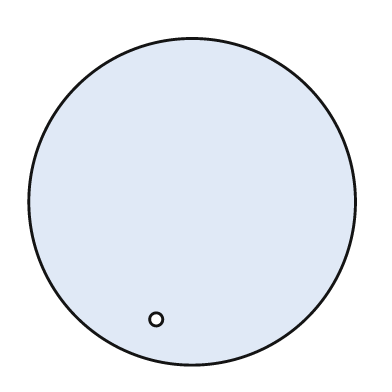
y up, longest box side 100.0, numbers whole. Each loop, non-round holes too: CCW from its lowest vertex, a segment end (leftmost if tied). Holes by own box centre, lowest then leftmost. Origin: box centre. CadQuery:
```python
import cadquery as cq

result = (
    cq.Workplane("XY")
    .moveTo(0.0, 0.0)
    .circle(50.0)
    .moveTo(-11.0, -36.0)
    .circle(2.0)
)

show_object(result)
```